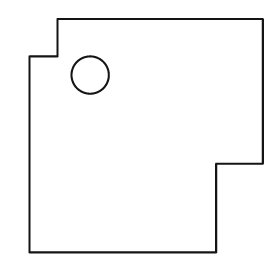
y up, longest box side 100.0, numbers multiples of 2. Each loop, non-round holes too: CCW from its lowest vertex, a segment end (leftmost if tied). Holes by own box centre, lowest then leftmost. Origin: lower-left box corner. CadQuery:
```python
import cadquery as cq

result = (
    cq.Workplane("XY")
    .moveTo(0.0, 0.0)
    .lineTo(80.0, 0.0)
    .lineTo(80.0, 38.0)
    .lineTo(100.0, 38.0)
    .lineTo(100.0, 100.0)
    .lineTo(12.0, 100.0)
    .lineTo(12.0, 84.0)
    .lineTo(0.0, 84.0)
    .close()
    .moveTo(26.0, 76.0)
    .circle(8.0)
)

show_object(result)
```